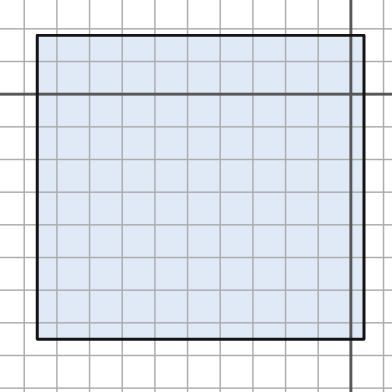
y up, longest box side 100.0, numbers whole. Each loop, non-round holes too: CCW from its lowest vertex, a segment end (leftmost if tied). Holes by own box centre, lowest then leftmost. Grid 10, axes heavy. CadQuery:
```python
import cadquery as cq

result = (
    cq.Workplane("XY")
    .moveTo(-96.0, -75.0)
    .lineTo(4.0, -75.0)
    .lineTo(4.0, 18.0)
    .lineTo(-96.0, 18.0)
    .close()
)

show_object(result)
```